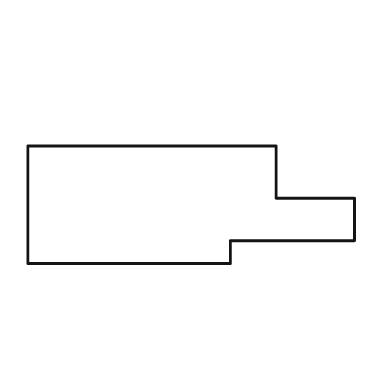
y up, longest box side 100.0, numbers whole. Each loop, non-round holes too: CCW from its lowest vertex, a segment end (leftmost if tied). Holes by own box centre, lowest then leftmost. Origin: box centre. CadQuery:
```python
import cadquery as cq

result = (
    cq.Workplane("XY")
    .moveTo(-50.0, -18.0)
    .lineTo(12.0, -18.0)
    .lineTo(12.0, -11.0)
    .lineTo(50.0, -11.0)
    .lineTo(50.0, 2.0)
    .lineTo(26.0, 2.0)
    .lineTo(26.0, 18.0)
    .lineTo(-50.0, 18.0)
    .close()
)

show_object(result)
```